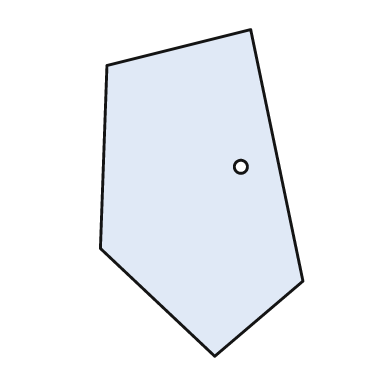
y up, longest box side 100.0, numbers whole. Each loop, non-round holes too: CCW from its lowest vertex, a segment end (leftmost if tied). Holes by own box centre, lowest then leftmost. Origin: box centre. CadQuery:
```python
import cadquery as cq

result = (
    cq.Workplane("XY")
    .moveTo(4.0, -50.0)
    .lineTo(31.0, -27.0)
    .lineTo(15.0, 50.0)
    .lineTo(-29.0, 39.0)
    .lineTo(-31.0, -17.0)
    .close()
    .moveTo(12.0, 8.0)
    .circle(2.0)
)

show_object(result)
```